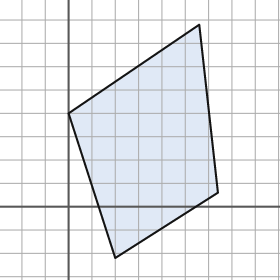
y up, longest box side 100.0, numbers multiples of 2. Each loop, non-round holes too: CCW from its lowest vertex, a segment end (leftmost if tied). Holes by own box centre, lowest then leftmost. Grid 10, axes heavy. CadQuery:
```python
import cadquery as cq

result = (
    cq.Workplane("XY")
    .moveTo(20.0, -22.0)
    .lineTo(64.0, 6.0)
    .lineTo(56.0, 78.0)
    .lineTo(0.0, 40.0)
    .close()
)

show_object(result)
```